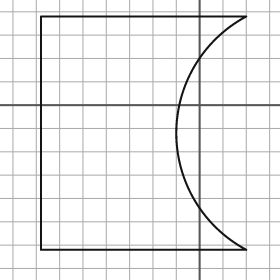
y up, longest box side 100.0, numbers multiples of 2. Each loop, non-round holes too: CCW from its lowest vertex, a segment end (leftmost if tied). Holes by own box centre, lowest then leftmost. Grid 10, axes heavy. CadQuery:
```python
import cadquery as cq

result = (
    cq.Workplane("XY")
    .moveTo(-68.0, -62.0)
    .lineTo(20.0, -62.0)
    .threePointArc((-10.0, -12.0), (20.0, 38.0))
    .lineTo(-68.0, 38.0)
    .close()
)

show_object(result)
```